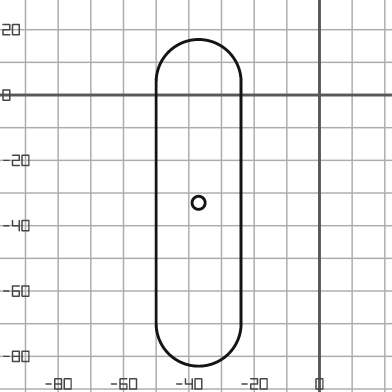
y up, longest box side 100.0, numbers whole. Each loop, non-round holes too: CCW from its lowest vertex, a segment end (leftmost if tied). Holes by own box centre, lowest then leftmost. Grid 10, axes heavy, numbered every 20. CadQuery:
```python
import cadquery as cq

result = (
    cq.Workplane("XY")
    .moveTo(-50.0, -70.0)
    .threePointArc((-37.0, -83.0), (-24.0, -70.0))
    .lineTo(-24.0, 4.0)
    .threePointArc((-37.0, 17.0), (-50.0, 4.0))
    .close()
    .moveTo(-37.0, -33.0)
    .circle(2.0)
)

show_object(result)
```